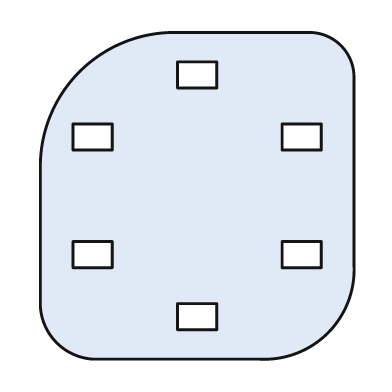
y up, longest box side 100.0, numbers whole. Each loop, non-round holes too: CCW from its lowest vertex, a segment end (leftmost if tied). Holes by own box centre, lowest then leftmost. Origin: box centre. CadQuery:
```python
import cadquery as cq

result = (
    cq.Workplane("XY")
    .moveTo(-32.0, -50.0)
    .lineTo(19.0, -50.0)
    .threePointArc((40.0, -42.0), (48.0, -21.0))
    .lineTo(48.0, 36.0)
    .threePointArc((44.0, 46.0), (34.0, 50.0))
    .lineTo(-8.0, 50.0)
    .threePointArc((-36.0, 38.0), (-48.0, 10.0))
    .lineTo(-48.0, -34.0)
    .threePointArc((-43.0, -45.0), (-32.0, -50.0))
    .close()
    .moveTo(-6.0, -41.0)
    .lineTo(6.0, -41.0)
    .lineTo(6.0, -33.0)
    .lineTo(-6.0, -33.0)
    .close()
    .moveTo(-38.0, -22.0)
    .lineTo(-26.0, -22.0)
    .lineTo(-26.0, -14.0)
    .lineTo(-38.0, -14.0)
    .close()
    .moveTo(26.0, -22.0)
    .lineTo(38.0, -22.0)
    .lineTo(38.0, -14.0)
    .lineTo(26.0, -14.0)
    .close()
    .moveTo(-38.0, 14.0)
    .lineTo(-26.0, 14.0)
    .lineTo(-26.0, 22.0)
    .lineTo(-38.0, 22.0)
    .close()
    .moveTo(26.0, 14.0)
    .lineTo(38.0, 14.0)
    .lineTo(38.0, 22.0)
    .lineTo(26.0, 22.0)
    .close()
    .moveTo(-6.0, 33.0)
    .lineTo(6.0, 33.0)
    .lineTo(6.0, 41.0)
    .lineTo(-6.0, 41.0)
    .close()
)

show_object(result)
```